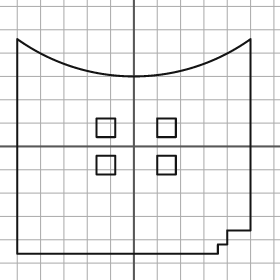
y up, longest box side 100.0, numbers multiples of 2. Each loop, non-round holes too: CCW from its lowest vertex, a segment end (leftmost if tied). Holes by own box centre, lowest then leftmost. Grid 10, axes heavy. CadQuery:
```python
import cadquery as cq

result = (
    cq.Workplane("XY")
    .moveTo(-50.0, -46.0)
    .lineTo(36.0, -46.0)
    .lineTo(36.0, -42.0)
    .lineTo(40.0, -42.0)
    .lineTo(40.0, -36.0)
    .lineTo(50.0, -36.0)
    .lineTo(50.0, 46.0)
    .threePointArc((0.0, 30.0), (-50.0, 46.0))
    .close()
    .moveTo(-16.0, -12.0)
    .lineTo(-8.0, -12.0)
    .lineTo(-8.0, -4.0)
    .lineTo(-16.0, -4.0)
    .close()
    .moveTo(10.0, -12.0)
    .lineTo(18.0, -12.0)
    .lineTo(18.0, -4.0)
    .lineTo(10.0, -4.0)
    .close()
    .moveTo(-16.0, 4.0)
    .lineTo(-8.0, 4.0)
    .lineTo(-8.0, 12.0)
    .lineTo(-16.0, 12.0)
    .close()
    .moveTo(10.0, 4.0)
    .lineTo(18.0, 4.0)
    .lineTo(18.0, 12.0)
    .lineTo(10.0, 12.0)
    .close()
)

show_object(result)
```